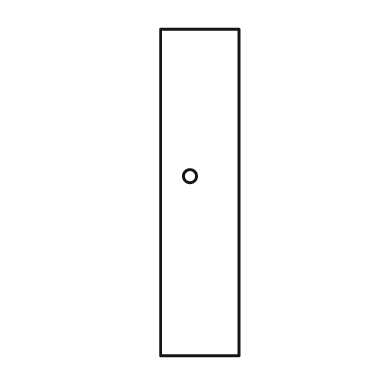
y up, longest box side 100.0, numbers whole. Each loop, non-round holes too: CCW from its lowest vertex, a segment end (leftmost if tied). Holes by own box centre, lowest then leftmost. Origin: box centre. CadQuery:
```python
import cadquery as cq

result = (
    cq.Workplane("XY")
    .moveTo(-12.0, -50.0)
    .lineTo(12.0, -50.0)
    .lineTo(12.0, 50.0)
    .lineTo(-12.0, 50.0)
    .close()
    .moveTo(-3.0, 5.0)
    .circle(2.0)
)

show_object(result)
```